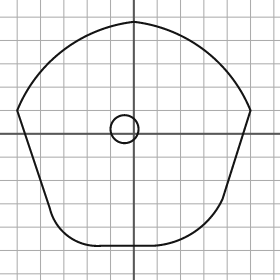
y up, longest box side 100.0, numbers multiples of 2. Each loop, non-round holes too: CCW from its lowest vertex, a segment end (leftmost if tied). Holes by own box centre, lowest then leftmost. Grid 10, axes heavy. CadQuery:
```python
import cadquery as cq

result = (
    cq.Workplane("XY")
    .moveTo(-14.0, -48.0)
    .lineTo(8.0, -48.0)
    .threePointArc((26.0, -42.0), (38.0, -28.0))
    .lineTo(50.0, 10.0)
    .threePointArc((30.0, 36.0), (0.0, 48.0))
    .threePointArc((-30.0, 36.0), (-50.0, 10.0))
    .lineTo(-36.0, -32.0)
    .threePointArc((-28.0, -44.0), (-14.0, -48.0))
    .close()
    .moveTo(-4.0, 2.0)
    .circle(6.0)
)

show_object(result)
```